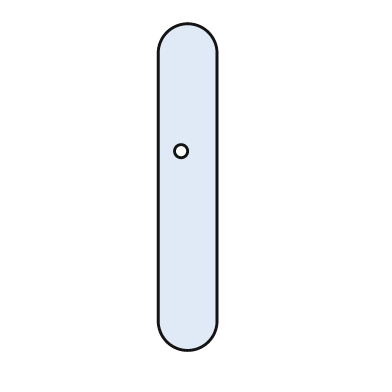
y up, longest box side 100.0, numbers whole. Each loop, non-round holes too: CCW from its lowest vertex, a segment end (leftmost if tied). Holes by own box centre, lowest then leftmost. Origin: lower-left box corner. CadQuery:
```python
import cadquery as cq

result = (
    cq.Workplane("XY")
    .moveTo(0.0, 9.0)
    .threePointArc((9.0, 0.0), (18.0, 9.0))
    .lineTo(18.0, 91.0)
    .threePointArc((9.0, 100.0), (0.0, 91.0))
    .close()
    .moveTo(7.0, 61.0)
    .circle(2.0)
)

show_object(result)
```